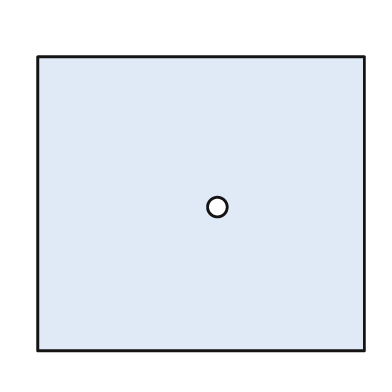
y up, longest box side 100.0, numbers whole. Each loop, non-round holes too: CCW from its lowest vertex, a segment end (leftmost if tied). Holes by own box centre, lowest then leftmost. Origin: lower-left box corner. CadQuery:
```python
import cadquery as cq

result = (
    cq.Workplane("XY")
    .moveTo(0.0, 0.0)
    .lineTo(100.0, 0.0)
    .lineTo(100.0, 90.0)
    .lineTo(0.0, 90.0)
    .close()
    .moveTo(55.0, 44.0)
    .circle(3.0)
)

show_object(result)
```